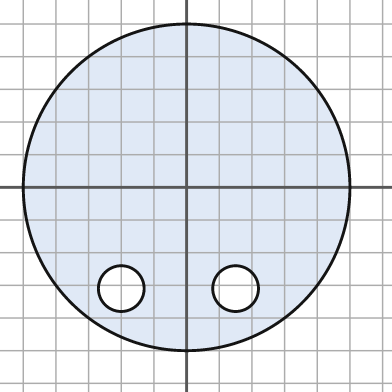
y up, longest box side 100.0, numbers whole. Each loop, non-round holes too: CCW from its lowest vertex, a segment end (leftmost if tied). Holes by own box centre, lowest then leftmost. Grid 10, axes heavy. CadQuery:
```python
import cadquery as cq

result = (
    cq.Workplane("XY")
    .moveTo(0.0, 0.0)
    .circle(50.0)
    .moveTo(-20.0, -31.0)
    .circle(7.0)
    .moveTo(15.0, -31.0)
    .circle(7.0)
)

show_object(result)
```